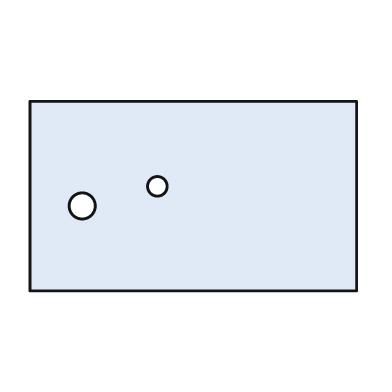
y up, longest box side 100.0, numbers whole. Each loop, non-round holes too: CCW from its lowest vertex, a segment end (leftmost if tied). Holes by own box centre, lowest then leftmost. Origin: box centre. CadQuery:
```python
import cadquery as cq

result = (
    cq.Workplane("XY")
    .moveTo(-50.0, -29.0)
    .lineTo(50.0, -29.0)
    .lineTo(50.0, 29.0)
    .lineTo(-50.0, 29.0)
    .close()
    .moveTo(-34.0, -3.0)
    .circle(4.0)
    .moveTo(-11.0, 3.0)
    .circle(3.0)
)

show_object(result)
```